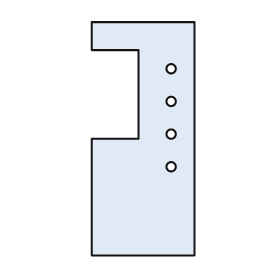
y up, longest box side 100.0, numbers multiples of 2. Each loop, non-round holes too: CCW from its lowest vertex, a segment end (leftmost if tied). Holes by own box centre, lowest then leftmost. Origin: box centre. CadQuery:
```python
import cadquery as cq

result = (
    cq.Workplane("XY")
    .moveTo(-22.0, -50.0)
    .lineTo(22.0, -50.0)
    .lineTo(22.0, 50.0)
    .lineTo(-22.0, 50.0)
    .lineTo(-22.0, 38.0)
    .lineTo(-2.0, 38.0)
    .lineTo(-2.0, 0.0)
    .lineTo(-22.0, 0.0)
    .close()
    .moveTo(12.0, -12.0)
    .circle(2.0)
    .moveTo(12.0, 2.0)
    .circle(2.0)
    .moveTo(12.0, 16.0)
    .circle(2.0)
    .moveTo(12.0, 30.0)
    .circle(2.0)
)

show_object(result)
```